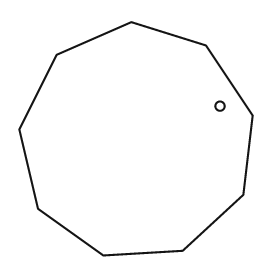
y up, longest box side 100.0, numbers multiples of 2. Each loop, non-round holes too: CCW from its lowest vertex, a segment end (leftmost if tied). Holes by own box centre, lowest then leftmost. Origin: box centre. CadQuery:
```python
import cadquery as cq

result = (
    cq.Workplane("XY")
    .moveTo(-14.0, -50.0)
    .lineTo(20.0, -48.0)
    .lineTo(46.0, -24.0)
    .lineTo(50.0, 10.0)
    .lineTo(30.0, 40.0)
    .lineTo(-2.0, 50.0)
    .lineTo(-34.0, 36.0)
    .lineTo(-50.0, 4.0)
    .lineTo(-42.0, -30.0)
    .close()
    .moveTo(36.0, 14.0)
    .circle(2.0)
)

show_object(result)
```